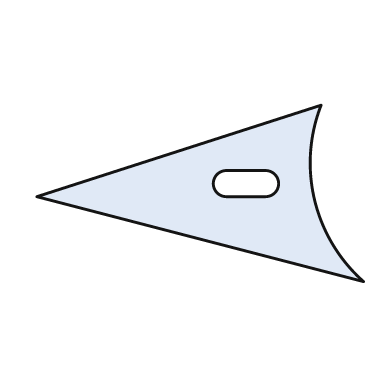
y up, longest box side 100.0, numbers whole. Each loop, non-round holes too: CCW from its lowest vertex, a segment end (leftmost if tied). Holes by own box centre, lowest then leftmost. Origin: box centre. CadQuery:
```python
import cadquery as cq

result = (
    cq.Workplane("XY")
    .moveTo(50.0, -27.0)
    .threePointArc((35.0, -2.0), (37.0, 27.0))
    .lineTo(-50.0, -1.0)
    .close()
    .moveTo(8.0, -1.0)
    .lineTo(20.0, -1.0)
    .threePointArc((24.0, 3.0), (20.0, 7.0))
    .lineTo(8.0, 7.0)
    .threePointArc((4.0, 3.0), (8.0, -1.0))
    .close()
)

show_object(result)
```